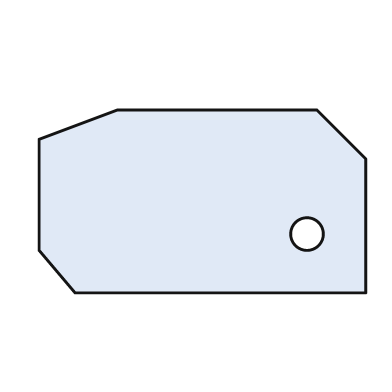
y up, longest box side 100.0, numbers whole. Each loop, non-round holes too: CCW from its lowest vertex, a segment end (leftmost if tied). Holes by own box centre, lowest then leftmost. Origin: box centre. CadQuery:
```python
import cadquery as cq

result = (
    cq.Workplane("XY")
    .moveTo(-39.0, -28.0)
    .lineTo(50.0, -28.0)
    .lineTo(50.0, 13.0)
    .lineTo(35.0, 28.0)
    .lineTo(-26.0, 28.0)
    .lineTo(-50.0, 19.0)
    .lineTo(-50.0, -15.0)
    .close()
    .moveTo(32.0, -10.0)
    .circle(5.0)
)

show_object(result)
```